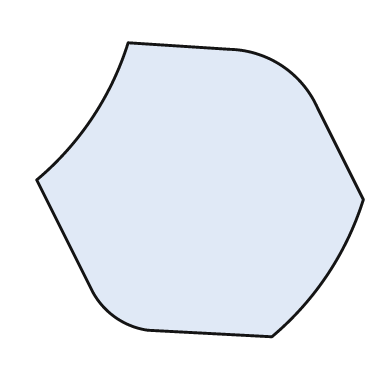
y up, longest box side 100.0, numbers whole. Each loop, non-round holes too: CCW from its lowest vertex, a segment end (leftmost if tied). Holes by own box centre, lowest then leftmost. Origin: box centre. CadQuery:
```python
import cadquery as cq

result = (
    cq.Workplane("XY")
    .moveTo(22.0, -45.0)
    .threePointArc((39.0, -26.0), (50.0, -3.0))
    .lineTo(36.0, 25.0)
    .threePointArc((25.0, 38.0), (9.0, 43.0))
    .lineTo(-22.0, 45.0)
    .threePointArc((-33.0, 22.0), (-50.0, 3.0))
    .lineTo(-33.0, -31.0)
    .threePointArc((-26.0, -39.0), (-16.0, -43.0))
    .close()
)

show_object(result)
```